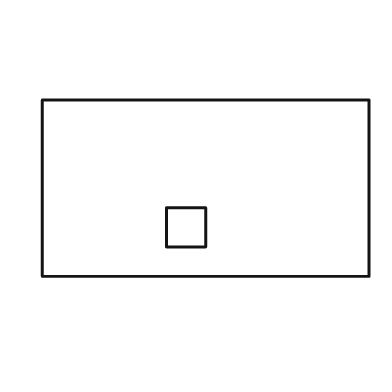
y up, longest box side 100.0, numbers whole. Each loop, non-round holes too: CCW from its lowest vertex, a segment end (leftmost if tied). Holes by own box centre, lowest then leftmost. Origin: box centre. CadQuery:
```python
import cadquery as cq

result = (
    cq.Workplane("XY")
    .moveTo(-50.0, -27.0)
    .lineTo(50.0, -27.0)
    .lineTo(50.0, 27.0)
    .lineTo(-50.0, 27.0)
    .close()
    .moveTo(-12.0, -18.0)
    .lineTo(0.0, -18.0)
    .lineTo(0.0, -6.0)
    .lineTo(-12.0, -6.0)
    .close()
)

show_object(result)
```